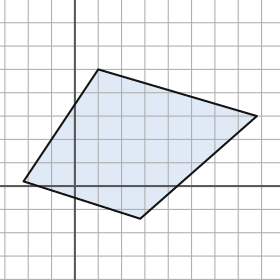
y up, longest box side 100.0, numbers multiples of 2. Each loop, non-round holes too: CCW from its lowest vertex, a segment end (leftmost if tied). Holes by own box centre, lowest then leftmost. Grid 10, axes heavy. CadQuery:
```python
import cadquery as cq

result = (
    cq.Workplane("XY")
    .moveTo(28.0, -14.0)
    .lineTo(78.0, 30.0)
    .lineTo(10.0, 50.0)
    .lineTo(-22.0, 2.0)
    .close()
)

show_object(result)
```